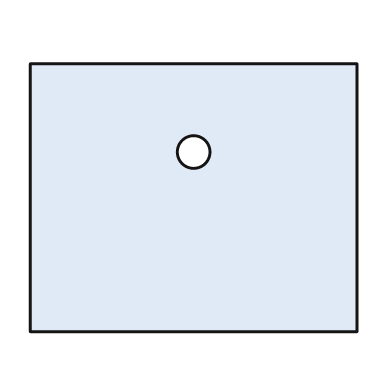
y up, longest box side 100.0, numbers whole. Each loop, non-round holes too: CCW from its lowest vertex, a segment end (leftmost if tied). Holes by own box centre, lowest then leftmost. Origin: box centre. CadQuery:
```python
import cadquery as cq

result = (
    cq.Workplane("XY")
    .moveTo(-50.0, -41.0)
    .lineTo(50.0, -41.0)
    .lineTo(50.0, 41.0)
    .lineTo(-50.0, 41.0)
    .close()
    .moveTo(0.0, 14.0)
    .circle(5.0)
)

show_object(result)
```